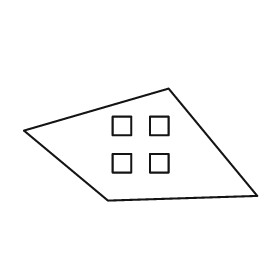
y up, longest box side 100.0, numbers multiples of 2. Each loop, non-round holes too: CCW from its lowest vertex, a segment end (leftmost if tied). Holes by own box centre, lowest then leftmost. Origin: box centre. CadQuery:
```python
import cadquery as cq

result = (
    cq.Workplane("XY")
    .moveTo(-14.0, -24.0)
    .lineTo(50.0, -22.0)
    .lineTo(12.0, 24.0)
    .lineTo(-50.0, 6.0)
    .close()
    .moveTo(-12.0, -12.0)
    .lineTo(-4.0, -12.0)
    .lineTo(-4.0, -4.0)
    .lineTo(-12.0, -4.0)
    .close()
    .moveTo(4.0, -12.0)
    .lineTo(12.0, -12.0)
    .lineTo(12.0, -4.0)
    .lineTo(4.0, -4.0)
    .close()
    .moveTo(-12.0, 4.0)
    .lineTo(-4.0, 4.0)
    .lineTo(-4.0, 12.0)
    .lineTo(-12.0, 12.0)
    .close()
    .moveTo(4.0, 4.0)
    .lineTo(12.0, 4.0)
    .lineTo(12.0, 12.0)
    .lineTo(4.0, 12.0)
    .close()
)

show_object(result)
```